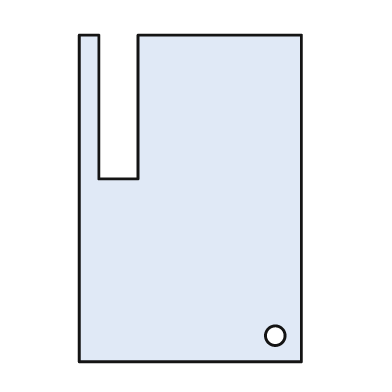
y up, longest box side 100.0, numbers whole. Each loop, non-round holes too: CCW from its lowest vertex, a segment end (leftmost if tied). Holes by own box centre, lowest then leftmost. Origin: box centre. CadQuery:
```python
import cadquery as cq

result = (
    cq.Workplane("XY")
    .moveTo(-34.0, -50.0)
    .lineTo(34.0, -50.0)
    .lineTo(34.0, 50.0)
    .lineTo(-16.0, 50.0)
    .lineTo(-16.0, 6.0)
    .lineTo(-28.0, 6.0)
    .lineTo(-28.0, 50.0)
    .lineTo(-34.0, 50.0)
    .close()
    .moveTo(26.0, -42.0)
    .circle(3.0)
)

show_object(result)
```